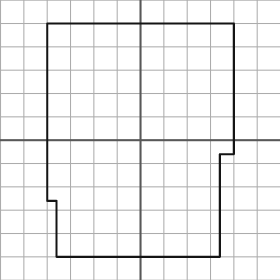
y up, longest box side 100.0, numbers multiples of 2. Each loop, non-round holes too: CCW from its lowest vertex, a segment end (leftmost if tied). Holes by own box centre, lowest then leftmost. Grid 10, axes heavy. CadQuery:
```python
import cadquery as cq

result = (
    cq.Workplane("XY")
    .moveTo(-36.0, -50.0)
    .lineTo(34.0, -50.0)
    .lineTo(34.0, -6.0)
    .lineTo(40.0, -6.0)
    .lineTo(40.0, 50.0)
    .lineTo(-40.0, 50.0)
    .lineTo(-40.0, -26.0)
    .lineTo(-36.0, -26.0)
    .close()
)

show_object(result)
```